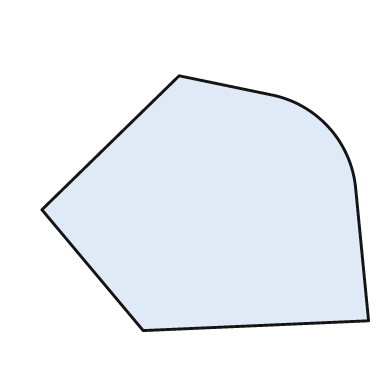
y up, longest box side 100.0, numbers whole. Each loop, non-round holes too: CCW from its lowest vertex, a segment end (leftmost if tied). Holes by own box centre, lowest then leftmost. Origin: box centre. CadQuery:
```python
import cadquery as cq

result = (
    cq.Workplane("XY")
    .moveTo(-19.0, -39.0)
    .lineTo(50.0, -36.0)
    .lineTo(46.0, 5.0)
    .threePointArc((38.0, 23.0), (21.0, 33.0))
    .lineTo(-8.0, 39.0)
    .lineTo(-50.0, -2.0)
    .close()
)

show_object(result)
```